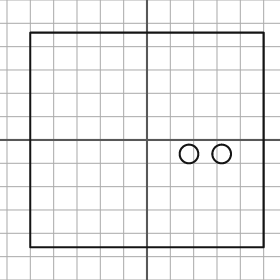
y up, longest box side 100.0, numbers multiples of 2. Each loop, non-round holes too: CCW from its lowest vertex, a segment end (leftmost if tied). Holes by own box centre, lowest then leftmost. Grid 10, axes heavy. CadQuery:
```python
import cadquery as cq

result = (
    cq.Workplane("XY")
    .moveTo(-50.0, -46.0)
    .lineTo(50.0, -46.0)
    .lineTo(50.0, 46.0)
    .lineTo(-50.0, 46.0)
    .close()
    .moveTo(18.0, -6.0)
    .circle(4.0)
    .moveTo(32.0, -6.0)
    .circle(4.0)
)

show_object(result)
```